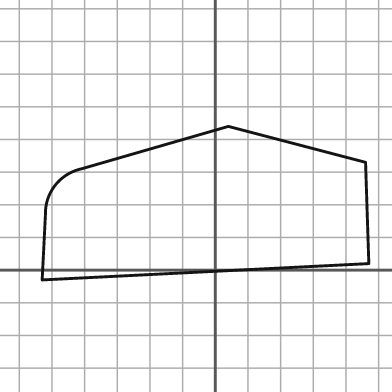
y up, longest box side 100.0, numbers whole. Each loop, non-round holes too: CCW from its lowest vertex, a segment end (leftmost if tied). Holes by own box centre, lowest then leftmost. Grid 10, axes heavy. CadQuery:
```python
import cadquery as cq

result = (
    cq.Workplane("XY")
    .moveTo(-53.0, -3.0)
    .lineTo(47.0, 2.0)
    .lineTo(46.0, 33.0)
    .lineTo(4.0, 44.0)
    .lineTo(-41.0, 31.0)
    .threePointArc((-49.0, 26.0), (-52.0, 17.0))
    .close()
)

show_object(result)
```